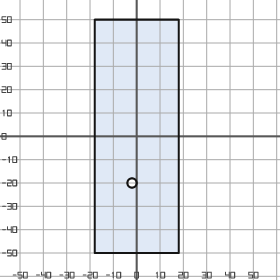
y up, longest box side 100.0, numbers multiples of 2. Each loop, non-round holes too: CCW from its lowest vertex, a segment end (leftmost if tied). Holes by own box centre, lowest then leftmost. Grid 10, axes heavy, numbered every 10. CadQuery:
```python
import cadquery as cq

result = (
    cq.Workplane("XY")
    .moveTo(-18.0, -50.0)
    .lineTo(18.0, -50.0)
    .lineTo(18.0, 50.0)
    .lineTo(-18.0, 50.0)
    .close()
    .moveTo(-2.0, -20.0)
    .circle(2.0)
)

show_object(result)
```